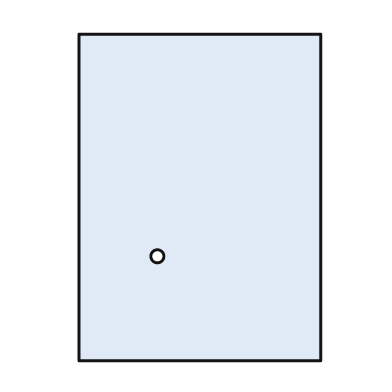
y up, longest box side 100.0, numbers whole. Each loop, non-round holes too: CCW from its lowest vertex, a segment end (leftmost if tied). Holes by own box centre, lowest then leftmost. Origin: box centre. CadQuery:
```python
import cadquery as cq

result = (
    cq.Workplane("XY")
    .moveTo(-37.0, -50.0)
    .lineTo(37.0, -50.0)
    .lineTo(37.0, 50.0)
    .lineTo(-37.0, 50.0)
    .close()
    .moveTo(-13.0, -18.0)
    .circle(2.0)
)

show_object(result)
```